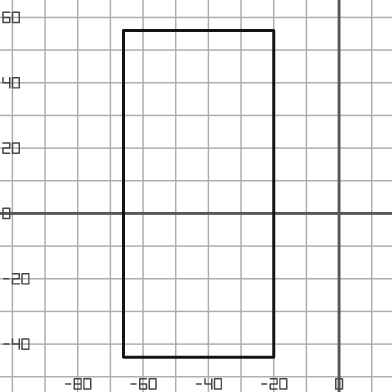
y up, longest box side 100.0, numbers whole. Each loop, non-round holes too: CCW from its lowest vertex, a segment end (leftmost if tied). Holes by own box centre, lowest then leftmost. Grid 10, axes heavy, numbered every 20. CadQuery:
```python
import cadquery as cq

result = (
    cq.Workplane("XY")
    .moveTo(-66.0, -44.0)
    .lineTo(-20.0, -44.0)
    .lineTo(-20.0, 56.0)
    .lineTo(-66.0, 56.0)
    .close()
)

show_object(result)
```